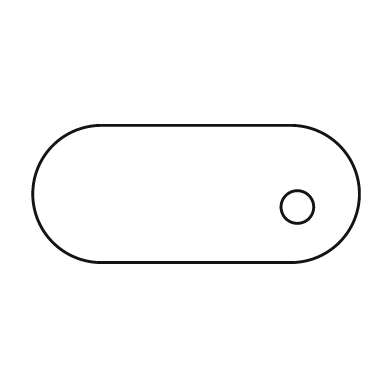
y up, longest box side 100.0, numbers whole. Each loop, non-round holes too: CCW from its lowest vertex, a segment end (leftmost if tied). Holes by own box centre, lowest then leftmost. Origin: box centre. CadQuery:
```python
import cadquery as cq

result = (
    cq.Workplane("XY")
    .moveTo(-29.0, -21.0)
    .lineTo(29.0, -21.0)
    .threePointArc((50.0, 0.0), (29.0, 21.0))
    .lineTo(-29.0, 21.0)
    .threePointArc((-50.0, 0.0), (-29.0, -21.0))
    .close()
    .moveTo(31.0, -4.0)
    .circle(5.0)
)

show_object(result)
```